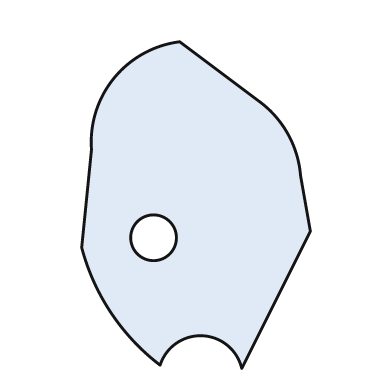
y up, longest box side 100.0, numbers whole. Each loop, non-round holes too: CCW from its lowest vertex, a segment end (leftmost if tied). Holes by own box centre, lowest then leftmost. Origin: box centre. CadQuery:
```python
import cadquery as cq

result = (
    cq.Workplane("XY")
    .moveTo(14.0, -50.0)
    .lineTo(35.0, -8.0)
    .lineTo(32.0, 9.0)
    .threePointArc((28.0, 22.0), (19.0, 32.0))
    .lineTo(-5.0, 50.0)
    .threePointArc((-25.0, 39.0), (-32.0, 17.0))
    .lineTo(-35.0, -13.0)
    .threePointArc((-26.0, -33.0), (-11.0, -49.0))
    .threePointArc((2.0, -40.0), (14.0, -50.0))
    .close()
    .moveTo(-13.0, -10.0)
    .circle(7.0)
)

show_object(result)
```